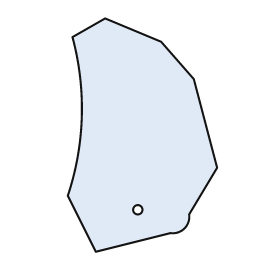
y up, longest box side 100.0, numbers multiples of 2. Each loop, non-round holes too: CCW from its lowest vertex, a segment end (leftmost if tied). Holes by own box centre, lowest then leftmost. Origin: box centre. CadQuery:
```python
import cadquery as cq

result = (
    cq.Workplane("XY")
    .moveTo(-20.0, -50.0)
    .lineTo(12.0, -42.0)
    .threePointArc((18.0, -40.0), (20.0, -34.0))
    .lineTo(32.0, -14.0)
    .lineTo(22.0, 24.0)
    .lineTo(8.0, 40.0)
    .lineTo(-16.0, 50.0)
    .lineTo(-30.0, 42.0)
    .threePointArc((-26.0, 8.0), (-32.0, -26.0))
    .close()
    .moveTo(-2.0, -32.0)
    .circle(2.0)
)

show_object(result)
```